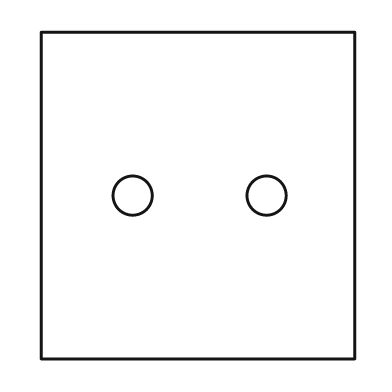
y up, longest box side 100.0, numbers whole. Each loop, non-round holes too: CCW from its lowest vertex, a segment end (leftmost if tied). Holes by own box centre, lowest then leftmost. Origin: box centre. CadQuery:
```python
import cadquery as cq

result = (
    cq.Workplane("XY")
    .moveTo(-48.0, -50.0)
    .lineTo(48.0, -50.0)
    .lineTo(48.0, 50.0)
    .lineTo(-48.0, 50.0)
    .close()
    .moveTo(-20.0, 0.0)
    .circle(6.0)
    .moveTo(21.0, 0.0)
    .circle(6.0)
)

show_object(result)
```